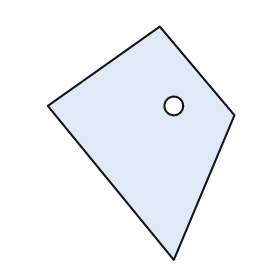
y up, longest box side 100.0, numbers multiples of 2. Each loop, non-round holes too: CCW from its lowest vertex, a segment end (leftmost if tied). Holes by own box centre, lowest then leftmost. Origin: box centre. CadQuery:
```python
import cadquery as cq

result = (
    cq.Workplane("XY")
    .moveTo(14.0, -50.0)
    .lineTo(40.0, 12.0)
    .lineTo(8.0, 50.0)
    .lineTo(-40.0, 16.0)
    .close()
    .moveTo(14.0, 16.0)
    .circle(4.0)
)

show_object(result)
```